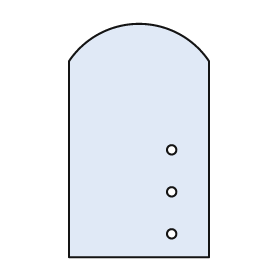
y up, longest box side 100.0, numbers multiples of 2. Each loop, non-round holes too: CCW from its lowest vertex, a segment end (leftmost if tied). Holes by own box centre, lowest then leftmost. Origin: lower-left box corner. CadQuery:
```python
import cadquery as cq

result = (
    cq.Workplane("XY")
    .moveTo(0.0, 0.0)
    .lineTo(60.0, 0.0)
    .lineTo(60.0, 84.0)
    .threePointArc((30.0, 100.0), (0.0, 84.0))
    .close()
    .moveTo(44.0, 10.0)
    .circle(2.0)
    .moveTo(44.0, 28.0)
    .circle(2.0)
    .moveTo(44.0, 46.0)
    .circle(2.0)
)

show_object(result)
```